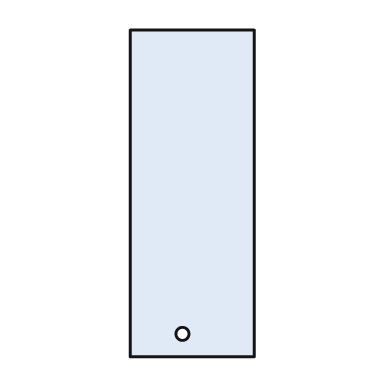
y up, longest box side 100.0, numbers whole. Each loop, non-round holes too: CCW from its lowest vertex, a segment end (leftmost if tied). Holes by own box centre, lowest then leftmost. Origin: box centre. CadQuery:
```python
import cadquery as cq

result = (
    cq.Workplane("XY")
    .moveTo(-19.0, -50.0)
    .lineTo(19.0, -50.0)
    .lineTo(19.0, 50.0)
    .lineTo(-19.0, 50.0)
    .close()
    .moveTo(-3.0, -43.0)
    .circle(2.0)
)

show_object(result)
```